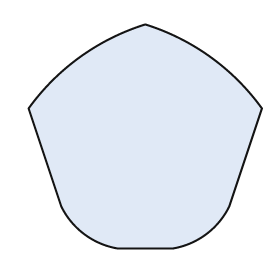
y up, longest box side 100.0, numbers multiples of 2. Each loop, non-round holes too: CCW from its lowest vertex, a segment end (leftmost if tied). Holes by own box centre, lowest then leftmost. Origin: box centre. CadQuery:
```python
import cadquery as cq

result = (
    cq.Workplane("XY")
    .moveTo(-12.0, -48.0)
    .lineTo(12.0, -48.0)
    .threePointArc((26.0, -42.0), (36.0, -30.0))
    .lineTo(50.0, 12.0)
    .threePointArc((28.0, 34.0), (0.0, 48.0))
    .threePointArc((-28.0, 34.0), (-50.0, 12.0))
    .lineTo(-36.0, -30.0)
    .threePointArc((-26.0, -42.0), (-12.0, -48.0))
    .close()
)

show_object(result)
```